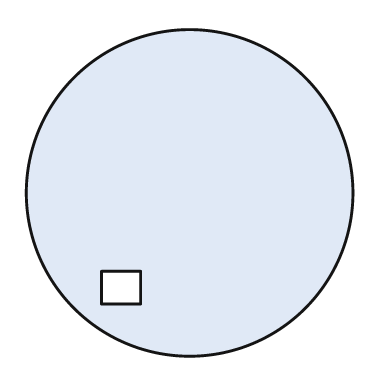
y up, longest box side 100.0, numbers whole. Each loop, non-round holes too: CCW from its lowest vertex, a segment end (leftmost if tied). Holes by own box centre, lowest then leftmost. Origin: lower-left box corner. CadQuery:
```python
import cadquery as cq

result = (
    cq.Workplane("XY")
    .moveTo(50.0, 50.0)
    .circle(50.0)
    .moveTo(23.0, 16.0)
    .lineTo(35.0, 16.0)
    .lineTo(35.0, 26.0)
    .lineTo(23.0, 26.0)
    .close()
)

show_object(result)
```